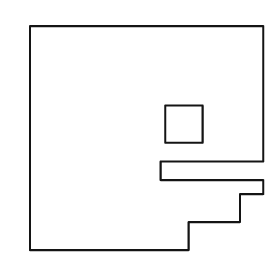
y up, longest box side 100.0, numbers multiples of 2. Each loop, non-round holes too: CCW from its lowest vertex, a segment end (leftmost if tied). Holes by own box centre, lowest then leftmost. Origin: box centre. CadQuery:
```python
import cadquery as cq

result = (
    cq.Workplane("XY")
    .moveTo(-50.0, -48.0)
    .lineTo(18.0, -48.0)
    .lineTo(18.0, -36.0)
    .lineTo(40.0, -36.0)
    .lineTo(40.0, -24.0)
    .lineTo(50.0, -24.0)
    .lineTo(50.0, -18.0)
    .lineTo(6.0, -18.0)
    .lineTo(6.0, -10.0)
    .lineTo(50.0, -10.0)
    .lineTo(50.0, 48.0)
    .lineTo(-50.0, 48.0)
    .close()
    .moveTo(8.0, -2.0)
    .lineTo(24.0, -2.0)
    .lineTo(24.0, 14.0)
    .lineTo(8.0, 14.0)
    .close()
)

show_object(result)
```